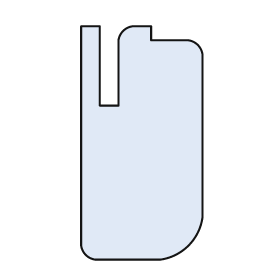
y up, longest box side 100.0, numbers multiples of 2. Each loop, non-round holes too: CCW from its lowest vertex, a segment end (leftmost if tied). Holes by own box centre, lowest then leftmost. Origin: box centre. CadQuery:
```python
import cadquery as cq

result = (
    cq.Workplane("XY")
    .moveTo(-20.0, -50.0)
    .lineTo(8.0, -50.0)
    .threePointArc((20.0, -44.0), (26.0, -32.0))
    .lineTo(26.0, 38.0)
    .threePointArc((24.0, 42.0), (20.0, 44.0))
    .lineTo(4.0, 44.0)
    .lineTo(4.0, 50.0)
    .lineTo(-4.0, 50.0)
    .threePointArc((-8.0, 48.0), (-10.0, 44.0))
    .lineTo(-10.0, 16.0)
    .lineTo(-18.0, 16.0)
    .lineTo(-18.0, 50.0)
    .lineTo(-26.0, 50.0)
    .lineTo(-26.0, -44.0)
    .threePointArc((-24.0, -48.0), (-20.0, -50.0))
    .close()
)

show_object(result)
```